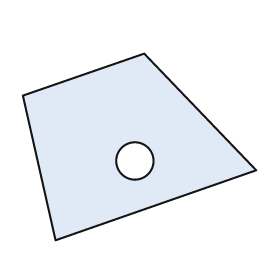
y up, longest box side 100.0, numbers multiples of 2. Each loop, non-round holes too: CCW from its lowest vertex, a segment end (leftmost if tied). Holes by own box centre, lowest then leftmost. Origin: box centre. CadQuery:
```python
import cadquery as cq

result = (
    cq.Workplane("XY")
    .moveTo(-36.0, -40.0)
    .lineTo(50.0, -10.0)
    .lineTo(2.0, 40.0)
    .lineTo(-50.0, 22.0)
    .close()
    .moveTo(-2.0, -6.0)
    .circle(8.0)
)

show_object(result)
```